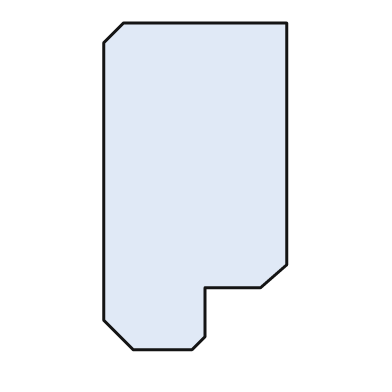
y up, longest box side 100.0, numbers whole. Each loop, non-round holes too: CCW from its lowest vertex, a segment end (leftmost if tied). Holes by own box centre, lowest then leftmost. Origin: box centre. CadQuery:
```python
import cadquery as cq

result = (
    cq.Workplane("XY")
    .moveTo(-19.0, -50.0)
    .lineTo(-1.0, -50.0)
    .lineTo(3.0, -46.0)
    .lineTo(3.0, -31.0)
    .lineTo(20.0, -31.0)
    .lineTo(28.0, -24.0)
    .lineTo(28.0, 50.0)
    .lineTo(-22.0, 50.0)
    .lineTo(-28.0, 44.0)
    .lineTo(-28.0, -41.0)
    .close()
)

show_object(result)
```